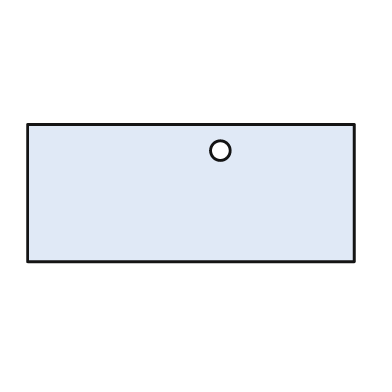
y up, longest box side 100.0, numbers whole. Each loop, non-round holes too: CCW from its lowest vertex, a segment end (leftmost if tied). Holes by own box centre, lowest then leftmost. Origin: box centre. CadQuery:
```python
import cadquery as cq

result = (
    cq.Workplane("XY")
    .moveTo(-50.0, -21.0)
    .lineTo(50.0, -21.0)
    .lineTo(50.0, 21.0)
    .lineTo(-50.0, 21.0)
    .close()
    .moveTo(9.0, 13.0)
    .circle(3.0)
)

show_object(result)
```